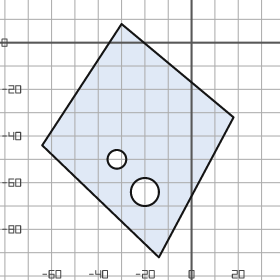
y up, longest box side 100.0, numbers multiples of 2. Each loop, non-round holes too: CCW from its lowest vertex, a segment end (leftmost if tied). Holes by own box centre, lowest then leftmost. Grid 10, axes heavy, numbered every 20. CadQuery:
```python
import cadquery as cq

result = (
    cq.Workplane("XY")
    .moveTo(-14.0, -92.0)
    .lineTo(18.0, -32.0)
    .lineTo(-30.0, 8.0)
    .lineTo(-64.0, -44.0)
    .close()
    .moveTo(-20.0, -64.0)
    .circle(6.0)
    .moveTo(-32.0, -50.0)
    .circle(4.0)
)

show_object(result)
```